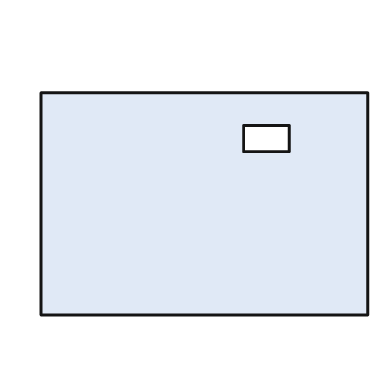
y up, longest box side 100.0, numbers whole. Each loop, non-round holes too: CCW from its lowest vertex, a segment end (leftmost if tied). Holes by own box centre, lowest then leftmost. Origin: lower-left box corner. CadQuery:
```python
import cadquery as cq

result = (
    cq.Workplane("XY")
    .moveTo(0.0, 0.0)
    .lineTo(100.0, 0.0)
    .lineTo(100.0, 68.0)
    .lineTo(0.0, 68.0)
    .close()
    .moveTo(62.0, 50.0)
    .lineTo(76.0, 50.0)
    .lineTo(76.0, 58.0)
    .lineTo(62.0, 58.0)
    .close()
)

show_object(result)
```